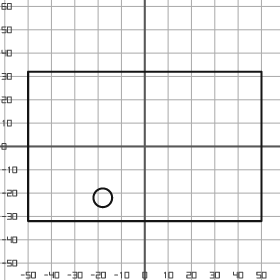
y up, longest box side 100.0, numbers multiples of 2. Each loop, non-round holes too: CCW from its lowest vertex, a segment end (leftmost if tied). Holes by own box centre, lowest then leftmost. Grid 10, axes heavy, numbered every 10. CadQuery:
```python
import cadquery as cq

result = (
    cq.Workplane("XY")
    .moveTo(-50.0, -32.0)
    .lineTo(50.0, -32.0)
    .lineTo(50.0, 32.0)
    .lineTo(-50.0, 32.0)
    .close()
    .moveTo(-18.0, -22.0)
    .circle(4.0)
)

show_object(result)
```